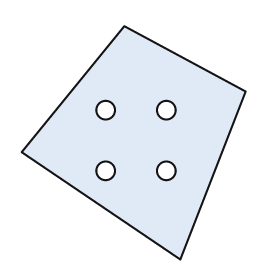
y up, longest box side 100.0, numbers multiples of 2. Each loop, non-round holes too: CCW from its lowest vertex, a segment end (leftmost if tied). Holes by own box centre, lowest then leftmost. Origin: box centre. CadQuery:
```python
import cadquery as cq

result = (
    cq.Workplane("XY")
    .moveTo(20.0, -50.0)
    .lineTo(48.0, 22.0)
    .lineTo(-4.0, 50.0)
    .lineTo(-48.0, -4.0)
    .close()
    .moveTo(-12.0, -12.0)
    .circle(4.0)
    .moveTo(14.0, -12.0)
    .circle(4.0)
    .moveTo(-12.0, 14.0)
    .circle(4.0)
    .moveTo(14.0, 14.0)
    .circle(4.0)
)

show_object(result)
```